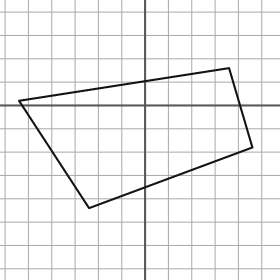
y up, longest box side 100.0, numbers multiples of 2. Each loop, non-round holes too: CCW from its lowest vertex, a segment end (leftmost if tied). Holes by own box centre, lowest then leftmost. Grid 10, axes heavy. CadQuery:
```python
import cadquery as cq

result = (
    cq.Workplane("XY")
    .moveTo(-24.0, -44.0)
    .lineTo(46.0, -18.0)
    .lineTo(36.0, 16.0)
    .lineTo(-54.0, 2.0)
    .close()
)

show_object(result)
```